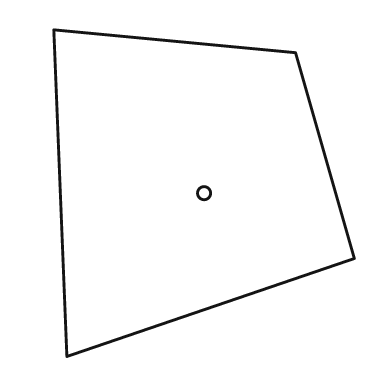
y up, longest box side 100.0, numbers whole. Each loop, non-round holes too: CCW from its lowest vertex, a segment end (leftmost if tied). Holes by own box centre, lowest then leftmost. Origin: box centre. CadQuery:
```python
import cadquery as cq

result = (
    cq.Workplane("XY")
    .moveTo(-42.0, -50.0)
    .lineTo(46.0, -20.0)
    .lineTo(28.0, 43.0)
    .lineTo(-46.0, 50.0)
    .close()
    .moveTo(0.0, 0.0)
    .circle(2.0)
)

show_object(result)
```